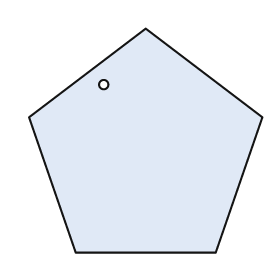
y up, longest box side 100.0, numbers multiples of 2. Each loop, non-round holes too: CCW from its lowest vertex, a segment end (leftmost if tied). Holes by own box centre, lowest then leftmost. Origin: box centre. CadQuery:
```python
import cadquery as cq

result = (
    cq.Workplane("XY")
    .moveTo(-30.0, -48.0)
    .lineTo(30.0, -48.0)
    .lineTo(50.0, 10.0)
    .lineTo(0.0, 48.0)
    .lineTo(-50.0, 10.0)
    .close()
    .moveTo(-18.0, 24.0)
    .circle(2.0)
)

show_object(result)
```